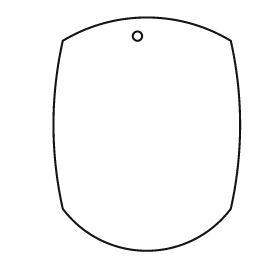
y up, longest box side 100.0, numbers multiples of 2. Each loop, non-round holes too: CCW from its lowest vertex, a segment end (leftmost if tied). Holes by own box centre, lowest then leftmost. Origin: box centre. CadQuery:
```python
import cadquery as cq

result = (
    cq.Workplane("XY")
    .moveTo(-36.0, -32.0)
    .threePointArc((0.0, -50.0), (36.0, -32.0))
    .threePointArc((40.0, 4.0), (36.0, 40.0))
    .threePointArc((0.0, 50.0), (-36.0, 40.0))
    .threePointArc((-40.0, 4.0), (-36.0, -32.0))
    .close()
    .moveTo(-4.0, 42.0)
    .circle(2.0)
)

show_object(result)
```